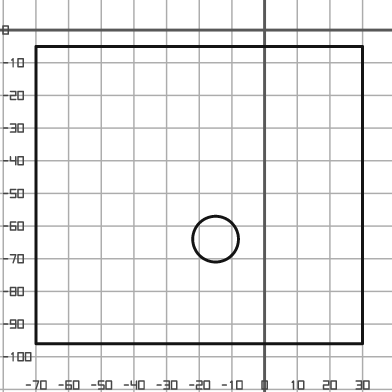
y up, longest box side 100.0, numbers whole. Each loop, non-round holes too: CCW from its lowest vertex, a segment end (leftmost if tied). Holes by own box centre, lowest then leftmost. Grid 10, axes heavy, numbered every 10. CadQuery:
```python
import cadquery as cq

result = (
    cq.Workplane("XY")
    .moveTo(-70.0, -96.0)
    .lineTo(30.0, -96.0)
    .lineTo(30.0, -5.0)
    .lineTo(-70.0, -5.0)
    .close()
    .moveTo(-15.0, -64.0)
    .circle(7.0)
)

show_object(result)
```